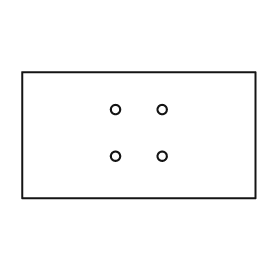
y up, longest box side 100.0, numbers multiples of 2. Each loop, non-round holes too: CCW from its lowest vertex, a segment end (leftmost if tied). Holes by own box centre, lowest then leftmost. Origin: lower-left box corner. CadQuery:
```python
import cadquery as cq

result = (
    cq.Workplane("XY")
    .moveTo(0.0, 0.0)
    .lineTo(100.0, 0.0)
    .lineTo(100.0, 54.0)
    .lineTo(0.0, 54.0)
    .close()
    .moveTo(40.0, 18.0)
    .circle(2.0)
    .moveTo(60.0, 18.0)
    .circle(2.0)
    .moveTo(40.0, 38.0)
    .circle(2.0)
    .moveTo(60.0, 38.0)
    .circle(2.0)
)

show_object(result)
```